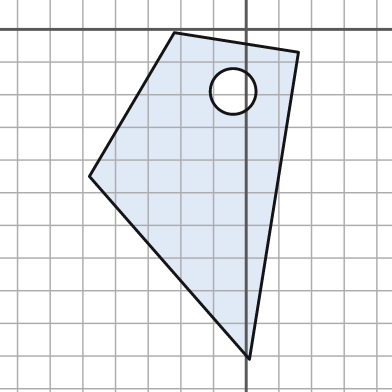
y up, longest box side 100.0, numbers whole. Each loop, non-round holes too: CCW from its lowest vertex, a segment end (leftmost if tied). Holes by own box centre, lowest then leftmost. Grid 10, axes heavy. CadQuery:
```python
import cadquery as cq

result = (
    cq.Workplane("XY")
    .moveTo(1.0, -101.0)
    .lineTo(16.0, -7.0)
    .lineTo(-22.0, -1.0)
    .lineTo(-48.0, -45.0)
    .close()
    .moveTo(-4.0, -19.0)
    .circle(7.0)
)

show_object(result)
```